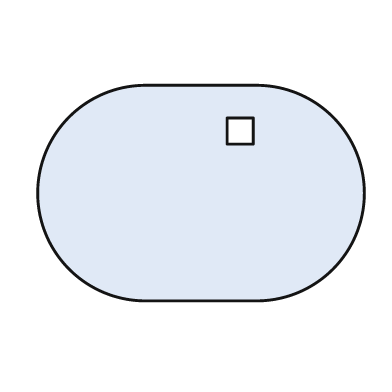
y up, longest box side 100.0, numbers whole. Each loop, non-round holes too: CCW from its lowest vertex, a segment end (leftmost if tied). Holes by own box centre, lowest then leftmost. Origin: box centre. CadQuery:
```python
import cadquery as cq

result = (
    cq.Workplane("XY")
    .moveTo(-17.0, -33.0)
    .lineTo(17.0, -33.0)
    .threePointArc((50.0, 0.0), (17.0, 33.0))
    .lineTo(-17.0, 33.0)
    .threePointArc((-50.0, 0.0), (-17.0, -33.0))
    .close()
    .moveTo(8.0, 15.0)
    .lineTo(16.0, 15.0)
    .lineTo(16.0, 23.0)
    .lineTo(8.0, 23.0)
    .close()
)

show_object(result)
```